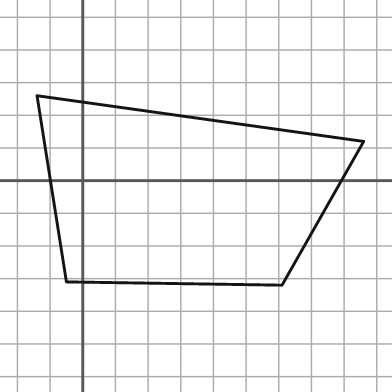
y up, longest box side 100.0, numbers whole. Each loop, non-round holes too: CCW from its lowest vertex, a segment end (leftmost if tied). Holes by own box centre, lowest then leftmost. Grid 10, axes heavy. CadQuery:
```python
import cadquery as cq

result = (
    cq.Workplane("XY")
    .moveTo(61.0, -32.0)
    .lineTo(86.0, 12.0)
    .lineTo(-14.0, 26.0)
    .lineTo(-5.0, -31.0)
    .close()
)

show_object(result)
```